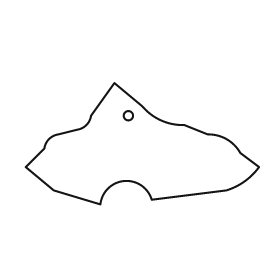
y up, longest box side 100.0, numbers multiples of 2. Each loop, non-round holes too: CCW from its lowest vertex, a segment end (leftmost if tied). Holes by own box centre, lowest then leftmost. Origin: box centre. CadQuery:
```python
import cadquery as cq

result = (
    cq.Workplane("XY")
    .moveTo(-18.0, -26.0)
    .threePointArc((-8.0, -16.0), (4.0, -24.0))
    .lineTo(36.0, -20.0)
    .threePointArc((44.0, -16.0), (50.0, -10.0))
    .lineTo(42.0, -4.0)
    .threePointArc((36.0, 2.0), (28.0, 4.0))
    .lineTo(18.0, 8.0)
    .threePointArc((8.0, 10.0), (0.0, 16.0))
    .lineTo(-12.0, 26.0)
    .lineTo(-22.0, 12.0)
    .threePointArc((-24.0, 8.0), (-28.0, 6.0))
    .lineTo(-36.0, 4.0)
    .threePointArc((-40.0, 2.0), (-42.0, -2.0))
    .lineTo(-50.0, -10.0)
    .lineTo(-38.0, -20.0)
    .close()
    .moveTo(-6.0, 12.0)
    .circle(2.0)
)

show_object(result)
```